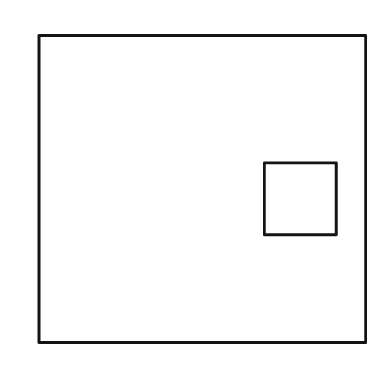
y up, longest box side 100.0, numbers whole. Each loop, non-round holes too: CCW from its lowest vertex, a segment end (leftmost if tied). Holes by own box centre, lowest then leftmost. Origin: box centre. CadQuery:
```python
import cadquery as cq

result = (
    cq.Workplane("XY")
    .moveTo(-50.0, -47.0)
    .lineTo(50.0, -47.0)
    .lineTo(50.0, 47.0)
    .lineTo(-50.0, 47.0)
    .close()
    .moveTo(19.0, -14.0)
    .lineTo(41.0, -14.0)
    .lineTo(41.0, 8.0)
    .lineTo(19.0, 8.0)
    .close()
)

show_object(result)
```